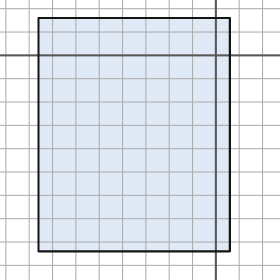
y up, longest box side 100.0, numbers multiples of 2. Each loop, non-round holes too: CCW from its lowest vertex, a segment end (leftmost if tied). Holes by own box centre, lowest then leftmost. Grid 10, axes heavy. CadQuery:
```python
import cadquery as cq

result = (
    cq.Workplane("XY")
    .moveTo(-76.0, -84.0)
    .lineTo(6.0, -84.0)
    .lineTo(6.0, 16.0)
    .lineTo(-76.0, 16.0)
    .close()
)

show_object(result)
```